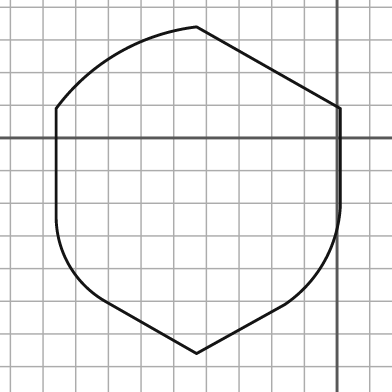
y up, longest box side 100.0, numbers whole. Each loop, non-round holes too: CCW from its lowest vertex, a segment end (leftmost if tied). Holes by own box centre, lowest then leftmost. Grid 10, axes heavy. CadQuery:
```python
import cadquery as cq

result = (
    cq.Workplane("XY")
    .moveTo(-43.0, -66.0)
    .lineTo(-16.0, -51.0)
    .threePointArc((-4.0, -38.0), (1.0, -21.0))
    .lineTo(1.0, 9.0)
    .lineTo(-43.0, 34.0)
    .threePointArc((-67.0, 26.0), (-86.0, 9.0))
    .lineTo(-86.0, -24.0)
    .threePointArc((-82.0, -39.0), (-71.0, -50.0))
    .close()
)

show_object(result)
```